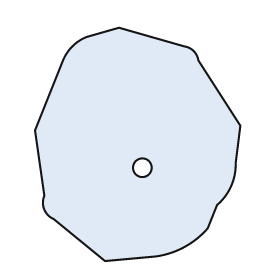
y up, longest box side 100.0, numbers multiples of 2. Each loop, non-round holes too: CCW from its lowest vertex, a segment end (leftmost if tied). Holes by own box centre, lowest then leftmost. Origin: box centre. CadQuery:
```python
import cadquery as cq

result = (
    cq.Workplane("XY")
    .moveTo(-14.0, -50.0)
    .lineTo(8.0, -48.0)
    .threePointArc((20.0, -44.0), (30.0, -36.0))
    .lineTo(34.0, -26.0)
    .threePointArc((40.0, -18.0), (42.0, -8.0))
    .lineTo(44.0, 8.0)
    .lineTo(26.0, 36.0)
    .threePointArc((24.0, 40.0), (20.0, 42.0))
    .lineTo(-8.0, 50.0)
    .lineTo(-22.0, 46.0)
    .threePointArc((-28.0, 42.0), (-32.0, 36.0))
    .lineTo(-44.0, 6.0)
    .lineTo(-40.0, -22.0)
    .threePointArc((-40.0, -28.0), (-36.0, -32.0))
    .close()
    .moveTo(2.0, -10.0)
    .circle(4.0)
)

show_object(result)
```